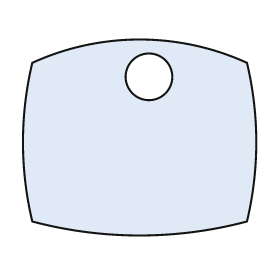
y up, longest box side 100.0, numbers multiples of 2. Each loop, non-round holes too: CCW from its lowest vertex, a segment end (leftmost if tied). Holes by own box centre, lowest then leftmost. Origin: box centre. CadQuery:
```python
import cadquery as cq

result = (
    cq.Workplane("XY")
    .moveTo(-46.0, -36.0)
    .threePointArc((0.0, -42.0), (46.0, -36.0))
    .threePointArc((50.0, -2.0), (46.0, 32.0))
    .threePointArc((0.0, 42.0), (-46.0, 32.0))
    .threePointArc((-50.0, -2.0), (-46.0, -36.0))
    .close()
    .moveTo(4.0, 26.0)
    .circle(10.0)
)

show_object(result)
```